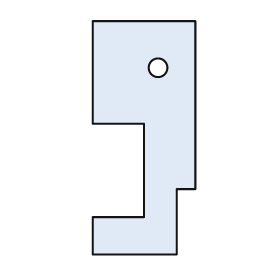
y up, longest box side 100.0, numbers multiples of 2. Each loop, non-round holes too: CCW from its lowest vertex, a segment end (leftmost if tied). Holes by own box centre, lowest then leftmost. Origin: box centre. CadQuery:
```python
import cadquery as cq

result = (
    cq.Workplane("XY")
    .moveTo(-22.0, -50.0)
    .lineTo(14.0, -50.0)
    .lineTo(14.0, -22.0)
    .lineTo(22.0, -22.0)
    .lineTo(22.0, 50.0)
    .lineTo(-22.0, 50.0)
    .lineTo(-22.0, 6.0)
    .lineTo(0.0, 6.0)
    .lineTo(0.0, -34.0)
    .lineTo(-22.0, -34.0)
    .close()
    .moveTo(6.0, 30.0)
    .circle(4.0)
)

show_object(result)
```